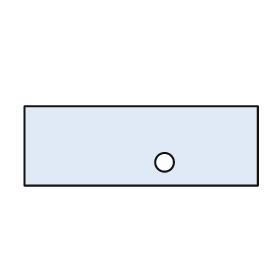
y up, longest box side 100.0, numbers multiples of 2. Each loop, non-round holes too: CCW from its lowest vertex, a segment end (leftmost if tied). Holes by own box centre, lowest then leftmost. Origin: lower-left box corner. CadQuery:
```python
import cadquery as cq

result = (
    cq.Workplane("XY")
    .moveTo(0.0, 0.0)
    .lineTo(100.0, 0.0)
    .lineTo(100.0, 34.0)
    .lineTo(0.0, 34.0)
    .close()
    .moveTo(60.0, 10.0)
    .circle(4.0)
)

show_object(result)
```